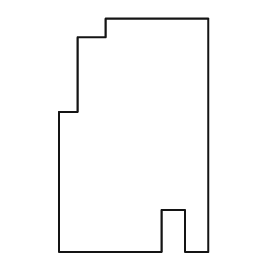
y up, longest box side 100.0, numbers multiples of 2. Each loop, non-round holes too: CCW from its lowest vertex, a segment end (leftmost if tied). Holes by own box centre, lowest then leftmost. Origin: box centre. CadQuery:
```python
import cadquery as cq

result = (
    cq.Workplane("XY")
    .moveTo(-32.0, -50.0)
    .lineTo(12.0, -50.0)
    .lineTo(12.0, -32.0)
    .lineTo(22.0, -32.0)
    .lineTo(22.0, -50.0)
    .lineTo(32.0, -50.0)
    .lineTo(32.0, 50.0)
    .lineTo(-12.0, 50.0)
    .lineTo(-12.0, 42.0)
    .lineTo(-24.0, 42.0)
    .lineTo(-24.0, 10.0)
    .lineTo(-32.0, 10.0)
    .close()
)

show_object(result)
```